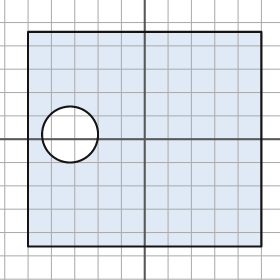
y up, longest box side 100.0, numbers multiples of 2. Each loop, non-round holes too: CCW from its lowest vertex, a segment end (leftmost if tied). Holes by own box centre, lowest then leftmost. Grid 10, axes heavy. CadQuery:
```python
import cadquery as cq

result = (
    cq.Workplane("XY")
    .moveTo(-50.0, -46.0)
    .lineTo(50.0, -46.0)
    .lineTo(50.0, 46.0)
    .lineTo(-50.0, 46.0)
    .close()
    .moveTo(-32.0, 2.0)
    .circle(12.0)
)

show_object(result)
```